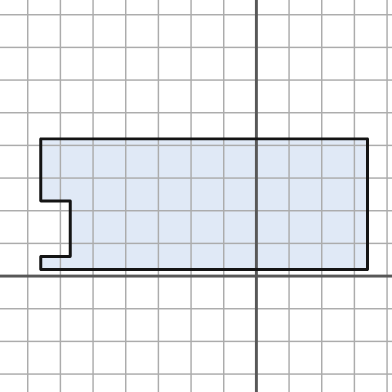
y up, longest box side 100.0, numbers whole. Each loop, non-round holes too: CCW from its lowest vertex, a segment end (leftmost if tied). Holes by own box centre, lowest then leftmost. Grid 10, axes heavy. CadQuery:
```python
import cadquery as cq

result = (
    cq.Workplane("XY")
    .moveTo(-66.0, 2.0)
    .lineTo(34.0, 2.0)
    .lineTo(34.0, 42.0)
    .lineTo(-66.0, 42.0)
    .lineTo(-66.0, 23.0)
    .lineTo(-57.0, 23.0)
    .lineTo(-57.0, 6.0)
    .lineTo(-66.0, 6.0)
    .close()
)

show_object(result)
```